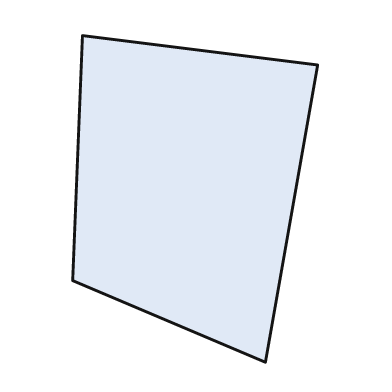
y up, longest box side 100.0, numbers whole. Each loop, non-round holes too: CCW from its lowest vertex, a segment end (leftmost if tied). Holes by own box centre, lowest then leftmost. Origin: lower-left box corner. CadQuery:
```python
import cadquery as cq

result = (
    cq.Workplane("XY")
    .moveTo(59.0, 0.0)
    .lineTo(75.0, 91.0)
    .lineTo(3.0, 100.0)
    .lineTo(0.0, 25.0)
    .close()
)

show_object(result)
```